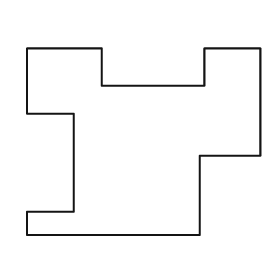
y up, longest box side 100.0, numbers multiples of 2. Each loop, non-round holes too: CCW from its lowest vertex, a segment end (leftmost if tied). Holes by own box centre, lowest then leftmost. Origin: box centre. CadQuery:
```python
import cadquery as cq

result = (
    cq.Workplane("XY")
    .moveTo(-50.0, -40.0)
    .lineTo(24.0, -40.0)
    .lineTo(24.0, -6.0)
    .lineTo(50.0, -6.0)
    .lineTo(50.0, 40.0)
    .lineTo(26.0, 40.0)
    .lineTo(26.0, 24.0)
    .lineTo(-18.0, 24.0)
    .lineTo(-18.0, 40.0)
    .lineTo(-50.0, 40.0)
    .lineTo(-50.0, 12.0)
    .lineTo(-30.0, 12.0)
    .lineTo(-30.0, -30.0)
    .lineTo(-50.0, -30.0)
    .close()
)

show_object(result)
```